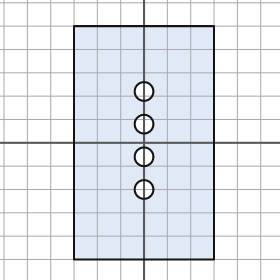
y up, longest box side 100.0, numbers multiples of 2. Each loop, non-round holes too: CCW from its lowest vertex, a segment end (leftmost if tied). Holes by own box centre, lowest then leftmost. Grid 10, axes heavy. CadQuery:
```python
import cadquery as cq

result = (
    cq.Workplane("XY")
    .moveTo(-30.0, -50.0)
    .lineTo(30.0, -50.0)
    .lineTo(30.0, 50.0)
    .lineTo(-30.0, 50.0)
    .close()
    .moveTo(0.0, -20.0)
    .circle(4.0)
    .moveTo(0.0, -6.0)
    .circle(4.0)
    .moveTo(0.0, 8.0)
    .circle(4.0)
    .moveTo(0.0, 22.0)
    .circle(4.0)
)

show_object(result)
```